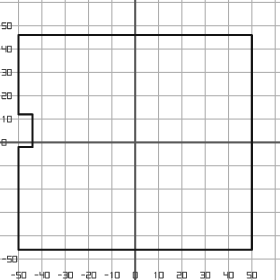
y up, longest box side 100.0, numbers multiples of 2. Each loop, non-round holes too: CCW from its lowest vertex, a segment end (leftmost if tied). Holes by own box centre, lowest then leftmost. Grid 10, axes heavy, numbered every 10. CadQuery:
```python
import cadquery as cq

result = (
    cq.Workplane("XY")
    .moveTo(-50.0, -46.0)
    .lineTo(50.0, -46.0)
    .lineTo(50.0, 46.0)
    .lineTo(-50.0, 46.0)
    .lineTo(-50.0, 12.0)
    .lineTo(-44.0, 12.0)
    .lineTo(-44.0, -2.0)
    .lineTo(-50.0, -2.0)
    .close()
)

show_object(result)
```